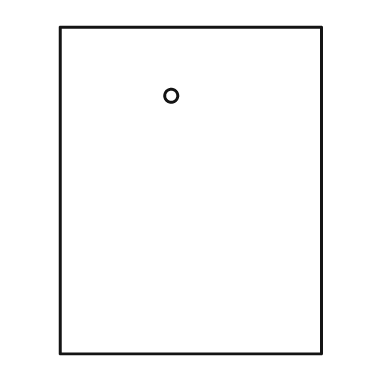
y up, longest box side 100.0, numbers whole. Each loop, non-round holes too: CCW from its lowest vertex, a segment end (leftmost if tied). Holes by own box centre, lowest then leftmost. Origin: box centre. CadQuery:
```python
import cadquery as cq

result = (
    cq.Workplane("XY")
    .moveTo(-40.0, -50.0)
    .lineTo(40.0, -50.0)
    .lineTo(40.0, 50.0)
    .lineTo(-40.0, 50.0)
    .close()
    .moveTo(-6.0, 29.0)
    .circle(2.0)
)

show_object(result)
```